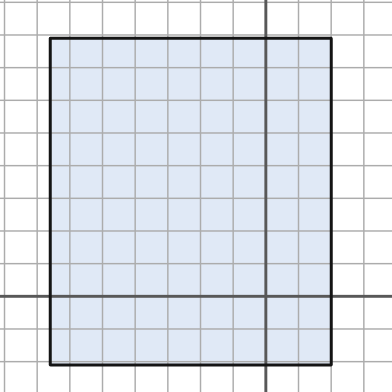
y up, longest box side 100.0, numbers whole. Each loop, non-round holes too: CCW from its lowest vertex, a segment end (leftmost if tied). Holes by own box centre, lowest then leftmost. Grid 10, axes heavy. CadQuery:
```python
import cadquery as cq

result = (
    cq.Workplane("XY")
    .moveTo(-66.0, -21.0)
    .lineTo(20.0, -21.0)
    .lineTo(20.0, 79.0)
    .lineTo(-66.0, 79.0)
    .close()
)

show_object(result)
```